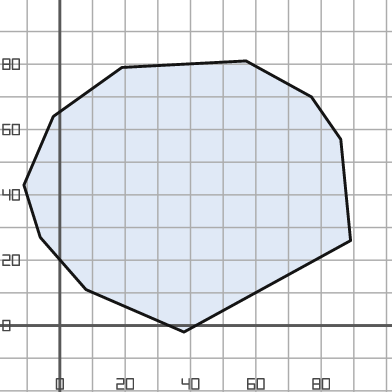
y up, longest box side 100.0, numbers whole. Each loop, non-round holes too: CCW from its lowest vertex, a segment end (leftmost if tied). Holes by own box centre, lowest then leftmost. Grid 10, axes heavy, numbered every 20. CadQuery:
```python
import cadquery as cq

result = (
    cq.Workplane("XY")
    .moveTo(38.0, -2.0)
    .lineTo(89.0, 26.0)
    .lineTo(86.0, 57.0)
    .lineTo(77.0, 70.0)
    .lineTo(57.0, 81.0)
    .lineTo(19.0, 79.0)
    .lineTo(-2.0, 64.0)
    .lineTo(-11.0, 43.0)
    .lineTo(-6.0, 27.0)
    .lineTo(8.0, 11.0)
    .close()
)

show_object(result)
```